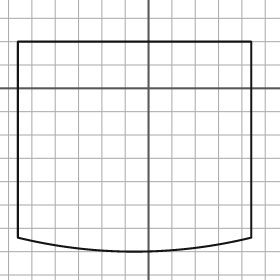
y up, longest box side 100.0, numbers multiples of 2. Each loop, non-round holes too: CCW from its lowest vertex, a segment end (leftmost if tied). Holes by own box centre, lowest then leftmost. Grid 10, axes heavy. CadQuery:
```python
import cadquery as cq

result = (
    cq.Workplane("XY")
    .moveTo(-56.0, -64.0)
    .threePointArc((-6.0, -70.0), (44.0, -64.0))
    .lineTo(44.0, 20.0)
    .lineTo(-56.0, 20.0)
    .close()
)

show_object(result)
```